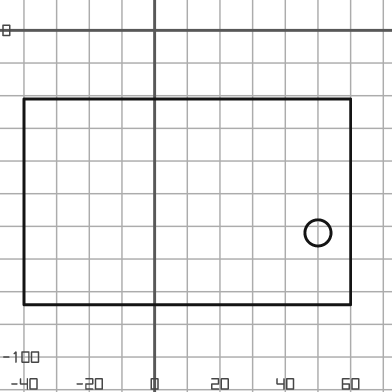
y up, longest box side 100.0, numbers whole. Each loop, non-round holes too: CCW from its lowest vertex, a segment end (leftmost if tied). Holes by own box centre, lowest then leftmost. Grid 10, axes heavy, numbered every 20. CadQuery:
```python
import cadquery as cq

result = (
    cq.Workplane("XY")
    .moveTo(-40.0, -84.0)
    .lineTo(60.0, -84.0)
    .lineTo(60.0, -21.0)
    .lineTo(-40.0, -21.0)
    .close()
    .moveTo(50.0, -62.0)
    .circle(4.0)
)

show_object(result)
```